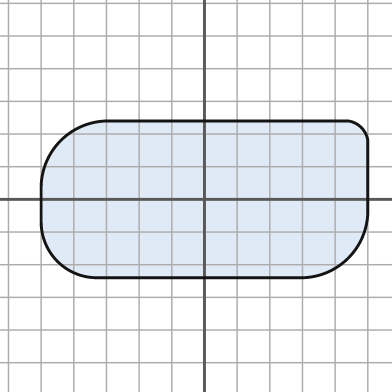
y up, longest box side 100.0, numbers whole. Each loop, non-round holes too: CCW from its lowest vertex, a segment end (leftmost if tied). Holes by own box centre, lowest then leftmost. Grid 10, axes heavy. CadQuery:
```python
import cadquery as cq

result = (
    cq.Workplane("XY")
    .moveTo(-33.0, -24.0)
    .lineTo(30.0, -24.0)
    .threePointArc((44.0, -18.0), (50.0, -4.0))
    .lineTo(50.0, 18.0)
    .threePointArc((48.0, 22.0), (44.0, 24.0))
    .lineTo(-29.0, 24.0)
    .threePointArc((-44.0, 18.0), (-50.0, 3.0))
    .lineTo(-50.0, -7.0)
    .threePointArc((-45.0, -19.0), (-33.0, -24.0))
    .close()
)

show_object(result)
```